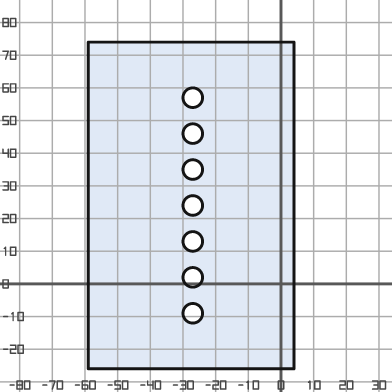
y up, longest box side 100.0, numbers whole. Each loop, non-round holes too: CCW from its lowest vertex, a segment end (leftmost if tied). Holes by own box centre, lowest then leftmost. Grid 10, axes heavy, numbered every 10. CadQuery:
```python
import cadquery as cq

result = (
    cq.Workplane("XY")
    .moveTo(-59.0, -26.0)
    .lineTo(4.0, -26.0)
    .lineTo(4.0, 74.0)
    .lineTo(-59.0, 74.0)
    .close()
    .moveTo(-27.0, -9.0)
    .circle(3.0)
    .moveTo(-27.0, 2.0)
    .circle(3.0)
    .moveTo(-27.0, 13.0)
    .circle(3.0)
    .moveTo(-27.0, 24.0)
    .circle(3.0)
    .moveTo(-27.0, 35.0)
    .circle(3.0)
    .moveTo(-27.0, 46.0)
    .circle(3.0)
    .moveTo(-27.0, 57.0)
    .circle(3.0)
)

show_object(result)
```